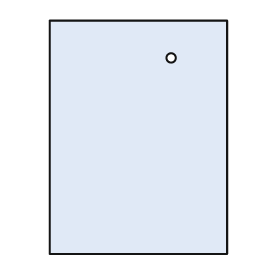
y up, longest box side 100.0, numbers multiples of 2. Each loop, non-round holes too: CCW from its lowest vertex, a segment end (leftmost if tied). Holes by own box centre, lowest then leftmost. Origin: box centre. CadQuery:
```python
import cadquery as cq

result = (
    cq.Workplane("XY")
    .moveTo(-38.0, -50.0)
    .lineTo(38.0, -50.0)
    .lineTo(38.0, 50.0)
    .lineTo(-38.0, 50.0)
    .close()
    .moveTo(14.0, 34.0)
    .circle(2.0)
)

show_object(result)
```